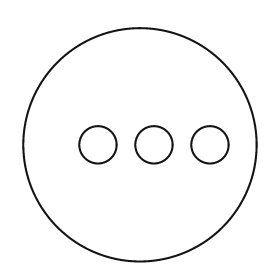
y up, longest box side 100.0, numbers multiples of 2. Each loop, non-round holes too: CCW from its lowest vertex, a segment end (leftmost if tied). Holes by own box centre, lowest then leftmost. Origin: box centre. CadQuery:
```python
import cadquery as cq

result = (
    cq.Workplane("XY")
    .moveTo(0.0, 0.0)
    .circle(50.0)
    .moveTo(-18.0, 0.0)
    .circle(8.0)
    .moveTo(6.0, 0.0)
    .circle(8.0)
    .moveTo(30.0, 0.0)
    .circle(8.0)
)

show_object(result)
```